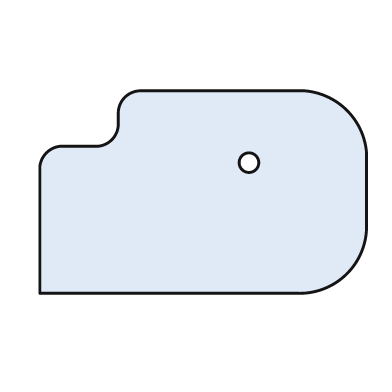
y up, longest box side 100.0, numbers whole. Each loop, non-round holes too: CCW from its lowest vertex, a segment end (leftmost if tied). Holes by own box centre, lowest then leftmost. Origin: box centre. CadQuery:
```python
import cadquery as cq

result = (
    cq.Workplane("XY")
    .moveTo(-50.0, -31.0)
    .lineTo(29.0, -31.0)
    .threePointArc((44.0, -25.0), (50.0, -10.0))
    .lineTo(50.0, 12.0)
    .threePointArc((44.0, 25.0), (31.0, 31.0))
    .lineTo(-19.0, 31.0)
    .threePointArc((-24.0, 29.0), (-26.0, 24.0))
    .lineTo(-26.0, 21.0)
    .threePointArc((-28.0, 16.0), (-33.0, 14.0))
    .lineTo(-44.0, 14.0)
    .threePointArc((-48.0, 12.0), (-50.0, 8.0))
    .close()
    .moveTo(14.0, 9.0)
    .circle(3.0)
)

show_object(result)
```